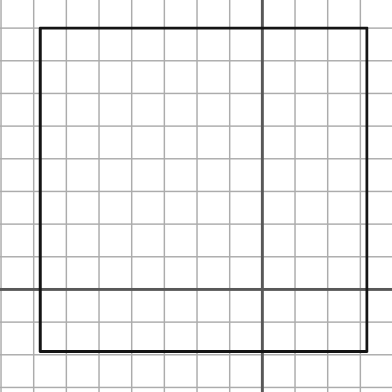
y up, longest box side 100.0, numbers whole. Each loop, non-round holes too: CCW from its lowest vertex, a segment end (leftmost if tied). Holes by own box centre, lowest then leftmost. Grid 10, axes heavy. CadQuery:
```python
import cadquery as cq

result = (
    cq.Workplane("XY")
    .moveTo(-68.0, -19.0)
    .lineTo(32.0, -19.0)
    .lineTo(32.0, 80.0)
    .lineTo(-68.0, 80.0)
    .close()
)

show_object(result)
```